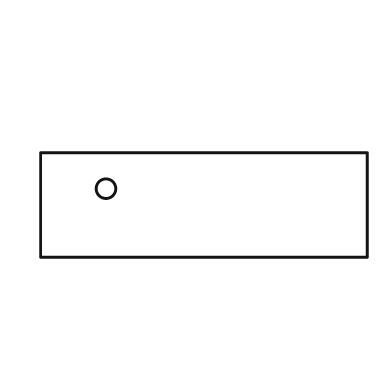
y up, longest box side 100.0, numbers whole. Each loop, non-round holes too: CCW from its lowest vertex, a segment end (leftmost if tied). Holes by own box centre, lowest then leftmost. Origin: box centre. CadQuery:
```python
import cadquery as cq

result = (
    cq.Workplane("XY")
    .moveTo(-50.0, -16.0)
    .lineTo(50.0, -16.0)
    .lineTo(50.0, 16.0)
    .lineTo(-50.0, 16.0)
    .close()
    .moveTo(-30.0, 5.0)
    .circle(3.0)
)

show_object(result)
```